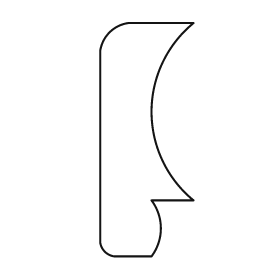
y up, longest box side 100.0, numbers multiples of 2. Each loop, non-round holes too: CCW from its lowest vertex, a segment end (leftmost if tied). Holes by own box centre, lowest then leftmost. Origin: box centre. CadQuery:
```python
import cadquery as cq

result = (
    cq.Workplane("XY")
    .moveTo(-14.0, -50.0)
    .lineTo(2.0, -50.0)
    .threePointArc((6.0, -38.0), (2.0, -26.0))
    .lineTo(20.0, -26.0)
    .threePointArc((2.0, 12.0), (20.0, 50.0))
    .lineTo(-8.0, 50.0)
    .threePointArc((-16.0, 46.0), (-20.0, 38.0))
    .lineTo(-20.0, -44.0)
    .threePointArc((-18.0, -48.0), (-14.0, -50.0))
    .close()
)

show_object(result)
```